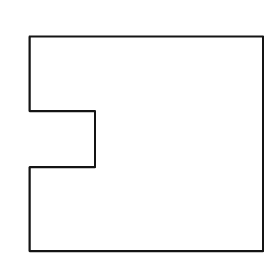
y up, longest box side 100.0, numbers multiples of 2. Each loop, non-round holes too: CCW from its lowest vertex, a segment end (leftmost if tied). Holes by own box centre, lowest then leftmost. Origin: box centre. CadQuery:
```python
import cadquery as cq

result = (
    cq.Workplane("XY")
    .moveTo(-50.0, -46.0)
    .lineTo(50.0, -46.0)
    .lineTo(50.0, 46.0)
    .lineTo(-50.0, 46.0)
    .lineTo(-50.0, 14.0)
    .lineTo(-22.0, 14.0)
    .lineTo(-22.0, -10.0)
    .lineTo(-50.0, -10.0)
    .close()
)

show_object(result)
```